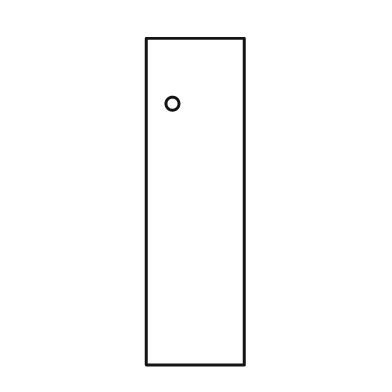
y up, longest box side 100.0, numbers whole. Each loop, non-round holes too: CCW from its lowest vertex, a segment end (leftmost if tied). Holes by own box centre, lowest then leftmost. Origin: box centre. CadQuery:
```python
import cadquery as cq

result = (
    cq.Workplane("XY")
    .moveTo(-15.0, -50.0)
    .lineTo(15.0, -50.0)
    .lineTo(15.0, 50.0)
    .lineTo(-15.0, 50.0)
    .close()
    .moveTo(-7.0, 30.0)
    .circle(2.0)
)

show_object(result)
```